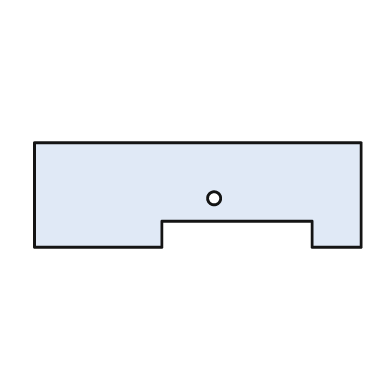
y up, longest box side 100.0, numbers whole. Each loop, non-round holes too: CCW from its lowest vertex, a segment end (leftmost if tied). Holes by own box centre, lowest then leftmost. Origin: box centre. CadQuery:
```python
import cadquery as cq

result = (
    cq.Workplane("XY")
    .moveTo(-50.0, -16.0)
    .lineTo(-11.0, -16.0)
    .lineTo(-11.0, -8.0)
    .lineTo(35.0, -8.0)
    .lineTo(35.0, -16.0)
    .lineTo(50.0, -16.0)
    .lineTo(50.0, 16.0)
    .lineTo(-50.0, 16.0)
    .close()
    .moveTo(5.0, -1.0)
    .circle(2.0)
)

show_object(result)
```